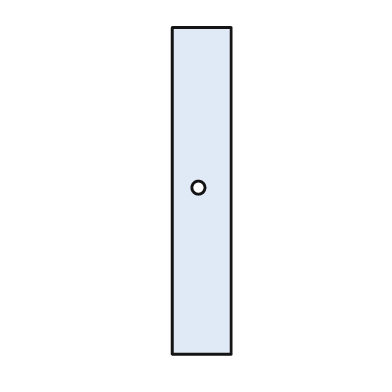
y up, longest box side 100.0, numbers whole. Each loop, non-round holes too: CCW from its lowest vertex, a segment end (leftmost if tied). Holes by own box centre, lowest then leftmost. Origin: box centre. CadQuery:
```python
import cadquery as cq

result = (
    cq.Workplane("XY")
    .moveTo(-9.0, -50.0)
    .lineTo(9.0, -50.0)
    .lineTo(9.0, 50.0)
    .lineTo(-9.0, 50.0)
    .close()
    .moveTo(-1.0, 1.0)
    .circle(2.0)
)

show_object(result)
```